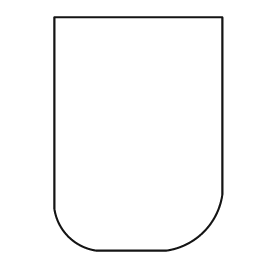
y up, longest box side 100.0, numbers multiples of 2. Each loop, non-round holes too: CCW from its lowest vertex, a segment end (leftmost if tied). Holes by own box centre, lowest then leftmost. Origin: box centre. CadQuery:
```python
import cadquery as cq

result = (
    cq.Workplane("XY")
    .moveTo(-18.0, -50.0)
    .lineTo(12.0, -50.0)
    .threePointArc((28.0, -42.0), (36.0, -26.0))
    .lineTo(36.0, 50.0)
    .lineTo(-36.0, 50.0)
    .lineTo(-36.0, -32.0)
    .threePointArc((-30.0, -44.0), (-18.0, -50.0))
    .close()
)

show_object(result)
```